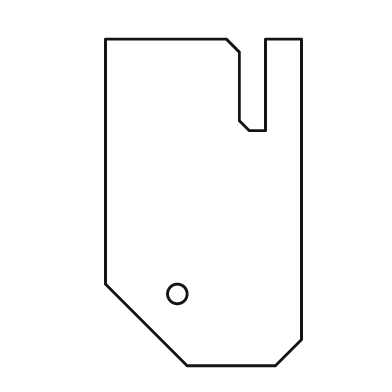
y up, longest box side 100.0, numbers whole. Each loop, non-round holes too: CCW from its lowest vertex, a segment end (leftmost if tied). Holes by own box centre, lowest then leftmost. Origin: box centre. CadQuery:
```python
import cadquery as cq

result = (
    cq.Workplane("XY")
    .moveTo(-5.0, -50.0)
    .lineTo(22.0, -50.0)
    .lineTo(30.0, -42.0)
    .lineTo(30.0, 50.0)
    .lineTo(19.0, 50.0)
    .lineTo(19.0, 22.0)
    .lineTo(14.0, 22.0)
    .lineTo(11.0, 25.0)
    .lineTo(11.0, 46.0)
    .lineTo(7.0, 50.0)
    .lineTo(-30.0, 50.0)
    .lineTo(-30.0, -25.0)
    .close()
    .moveTo(-8.0, -28.0)
    .circle(3.0)
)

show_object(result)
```